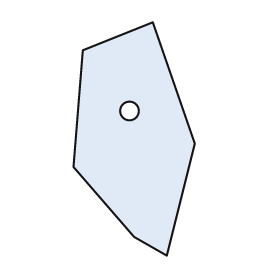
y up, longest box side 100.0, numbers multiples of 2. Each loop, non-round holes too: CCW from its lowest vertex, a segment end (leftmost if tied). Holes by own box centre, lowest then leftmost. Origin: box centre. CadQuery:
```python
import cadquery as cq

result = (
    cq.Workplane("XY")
    .moveTo(14.0, -50.0)
    .lineTo(26.0, -2.0)
    .lineTo(8.0, 50.0)
    .lineTo(-22.0, 38.0)
    .lineTo(-26.0, -12.0)
    .lineTo(0.0, -42.0)
    .close()
    .moveTo(-2.0, 12.0)
    .circle(4.0)
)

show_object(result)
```